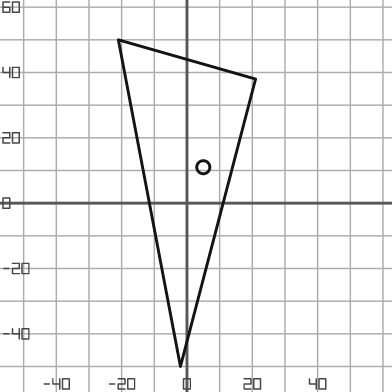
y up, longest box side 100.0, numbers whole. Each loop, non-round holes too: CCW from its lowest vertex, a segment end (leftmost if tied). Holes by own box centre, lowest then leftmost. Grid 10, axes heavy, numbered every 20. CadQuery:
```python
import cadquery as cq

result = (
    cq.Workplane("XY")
    .moveTo(-2.0, -50.0)
    .lineTo(21.0, 38.0)
    .lineTo(-21.0, 50.0)
    .close()
    .moveTo(5.0, 11.0)
    .circle(2.0)
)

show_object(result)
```